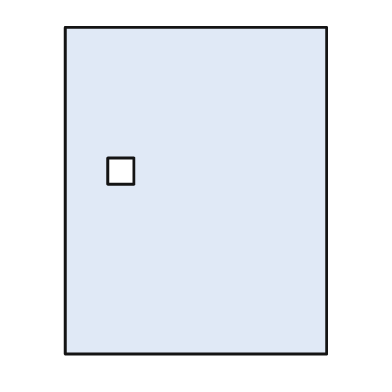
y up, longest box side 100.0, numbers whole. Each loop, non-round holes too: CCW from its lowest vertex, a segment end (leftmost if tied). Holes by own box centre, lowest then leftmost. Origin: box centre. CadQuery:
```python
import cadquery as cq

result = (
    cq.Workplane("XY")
    .moveTo(-40.0, -50.0)
    .lineTo(40.0, -50.0)
    .lineTo(40.0, 50.0)
    .lineTo(-40.0, 50.0)
    .close()
    .moveTo(-27.0, 2.0)
    .lineTo(-19.0, 2.0)
    .lineTo(-19.0, 10.0)
    .lineTo(-27.0, 10.0)
    .close()
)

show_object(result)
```